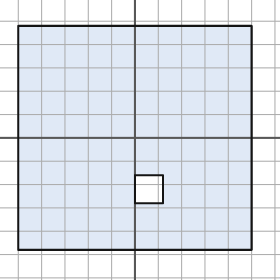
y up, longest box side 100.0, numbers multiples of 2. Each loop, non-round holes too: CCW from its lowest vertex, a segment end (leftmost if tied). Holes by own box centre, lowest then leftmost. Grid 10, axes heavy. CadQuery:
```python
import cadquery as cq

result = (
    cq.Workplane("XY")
    .moveTo(-50.0, -48.0)
    .lineTo(50.0, -48.0)
    .lineTo(50.0, 48.0)
    .lineTo(-50.0, 48.0)
    .close()
    .moveTo(0.0, -28.0)
    .lineTo(12.0, -28.0)
    .lineTo(12.0, -16.0)
    .lineTo(0.0, -16.0)
    .close()
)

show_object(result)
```